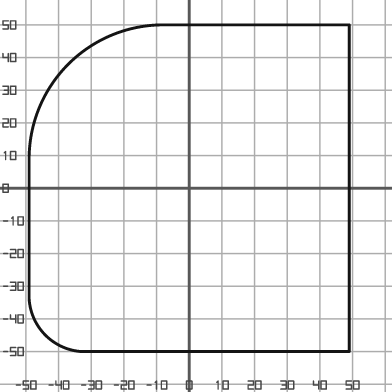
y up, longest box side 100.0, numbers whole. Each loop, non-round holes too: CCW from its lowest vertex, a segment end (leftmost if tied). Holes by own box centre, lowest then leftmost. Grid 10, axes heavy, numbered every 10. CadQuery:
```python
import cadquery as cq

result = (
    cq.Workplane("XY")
    .moveTo(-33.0, -50.0)
    .lineTo(49.0, -50.0)
    .lineTo(49.0, 50.0)
    .lineTo(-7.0, 50.0)
    .threePointArc((-37.0, 38.0), (-49.0, 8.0))
    .lineTo(-49.0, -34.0)
    .threePointArc((-44.0, -45.0), (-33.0, -50.0))
    .close()
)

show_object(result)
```